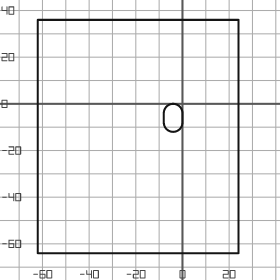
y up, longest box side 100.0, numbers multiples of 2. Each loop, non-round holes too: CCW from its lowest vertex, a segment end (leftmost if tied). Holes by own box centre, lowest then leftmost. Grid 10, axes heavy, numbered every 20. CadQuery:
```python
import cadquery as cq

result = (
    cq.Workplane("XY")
    .moveTo(-62.0, -64.0)
    .lineTo(24.0, -64.0)
    .lineTo(24.0, 36.0)
    .lineTo(-62.0, 36.0)
    .close()
    .moveTo(-8.0, -8.0)
    .threePointArc((-4.0, -12.0), (0.0, -8.0))
    .lineTo(0.0, -4.0)
    .threePointArc((-4.0, 0.0), (-8.0, -4.0))
    .close()
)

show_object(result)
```